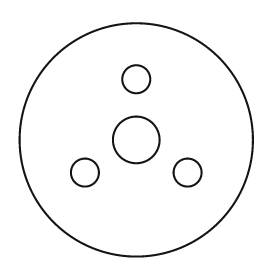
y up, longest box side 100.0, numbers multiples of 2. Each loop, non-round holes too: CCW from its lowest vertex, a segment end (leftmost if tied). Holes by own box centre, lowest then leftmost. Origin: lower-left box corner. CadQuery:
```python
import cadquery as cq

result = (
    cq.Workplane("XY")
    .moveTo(50.0, 50.0)
    .circle(50.0)
    .moveTo(28.0, 36.0)
    .circle(6.0)
    .moveTo(72.0, 36.0)
    .circle(6.0)
    .moveTo(50.0, 50.0)
    .circle(10.0)
    .moveTo(50.0, 76.0)
    .circle(6.0)
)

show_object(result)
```